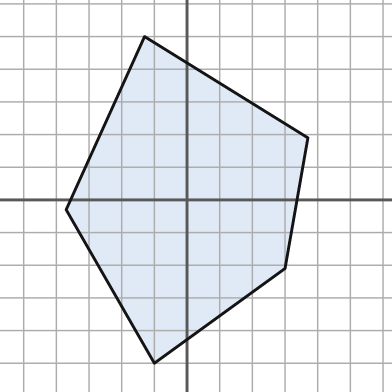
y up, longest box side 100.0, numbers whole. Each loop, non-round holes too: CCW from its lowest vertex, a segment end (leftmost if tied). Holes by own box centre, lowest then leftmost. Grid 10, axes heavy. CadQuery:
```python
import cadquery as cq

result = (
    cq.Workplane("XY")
    .moveTo(-10.0, -50.0)
    .lineTo(30.0, -21.0)
    .lineTo(37.0, 19.0)
    .lineTo(-13.0, 50.0)
    .lineTo(-37.0, -3.0)
    .close()
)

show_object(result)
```